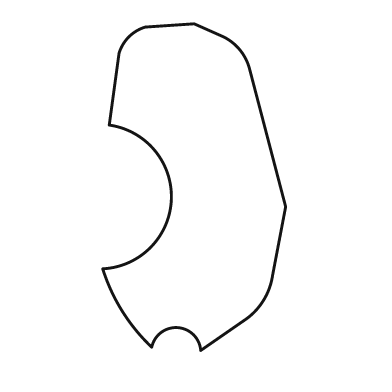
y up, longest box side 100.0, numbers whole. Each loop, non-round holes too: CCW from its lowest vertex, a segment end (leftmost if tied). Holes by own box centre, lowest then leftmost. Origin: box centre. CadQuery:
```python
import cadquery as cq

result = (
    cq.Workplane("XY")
    .moveTo(2.0, -50.0)
    .lineTo(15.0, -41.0)
    .threePointArc((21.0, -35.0), (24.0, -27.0))
    .lineTo(28.0, -6.0)
    .lineTo(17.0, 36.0)
    .threePointArc((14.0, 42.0), (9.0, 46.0))
    .lineTo(0.0, 50.0)
    .lineTo(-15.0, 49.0)
    .threePointArc((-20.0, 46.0), (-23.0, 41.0))
    .lineTo(-26.0, 19.0)
    .threePointArc((-7.0, -4.0), (-28.0, -25.0))
    .threePointArc((-22.0, -38.0), (-13.0, -49.0))
    .threePointArc((-5.0, -43.0), (2.0, -50.0))
    .close()
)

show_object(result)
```